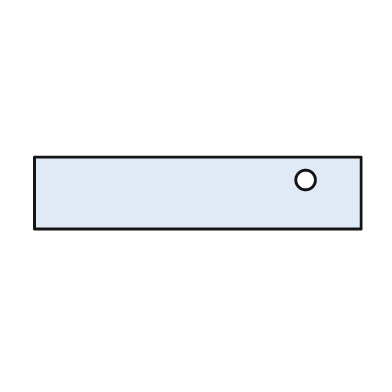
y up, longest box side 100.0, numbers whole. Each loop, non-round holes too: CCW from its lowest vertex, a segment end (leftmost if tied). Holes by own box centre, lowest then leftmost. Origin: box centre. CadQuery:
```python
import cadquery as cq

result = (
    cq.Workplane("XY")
    .moveTo(-50.0, -11.0)
    .lineTo(50.0, -11.0)
    .lineTo(50.0, 11.0)
    .lineTo(-50.0, 11.0)
    .close()
    .moveTo(33.0, 4.0)
    .circle(3.0)
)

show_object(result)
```